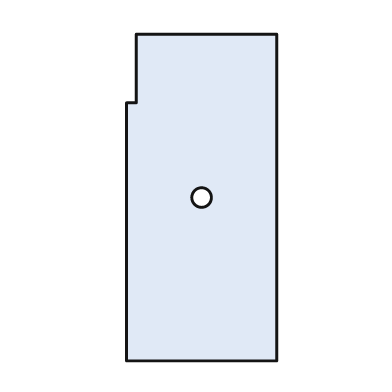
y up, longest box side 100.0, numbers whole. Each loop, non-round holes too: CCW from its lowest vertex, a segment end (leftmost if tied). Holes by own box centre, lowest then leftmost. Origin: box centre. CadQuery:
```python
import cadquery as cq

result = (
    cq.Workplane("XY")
    .moveTo(-23.0, -50.0)
    .lineTo(23.0, -50.0)
    .lineTo(23.0, 50.0)
    .lineTo(-20.0, 50.0)
    .lineTo(-20.0, 29.0)
    .lineTo(-23.0, 29.0)
    .close()
    .moveTo(0.0, 0.0)
    .circle(3.0)
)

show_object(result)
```